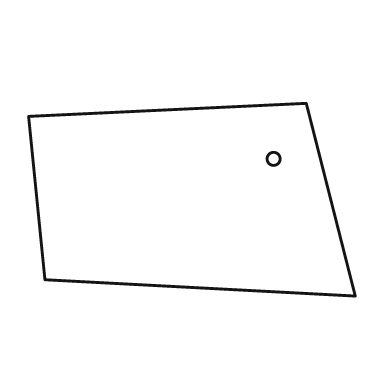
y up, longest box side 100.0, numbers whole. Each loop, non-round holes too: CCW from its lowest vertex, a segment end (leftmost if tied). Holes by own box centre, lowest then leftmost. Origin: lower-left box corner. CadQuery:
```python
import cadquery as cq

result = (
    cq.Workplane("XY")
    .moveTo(100.0, 0.0)
    .lineTo(85.0, 59.0)
    .lineTo(0.0, 55.0)
    .lineTo(5.0, 5.0)
    .close()
    .moveTo(75.0, 42.0)
    .circle(2.0)
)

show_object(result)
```